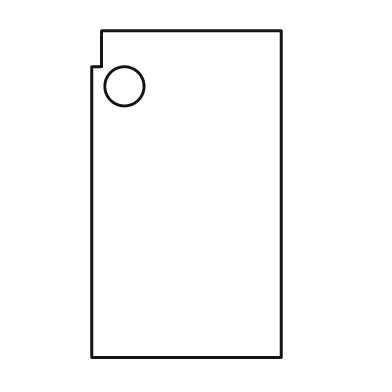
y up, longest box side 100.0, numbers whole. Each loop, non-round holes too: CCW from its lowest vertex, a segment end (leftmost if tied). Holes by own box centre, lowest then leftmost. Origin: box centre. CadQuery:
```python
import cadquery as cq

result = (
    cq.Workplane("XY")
    .moveTo(-29.0, -50.0)
    .lineTo(29.0, -50.0)
    .lineTo(29.0, 50.0)
    .lineTo(-26.0, 50.0)
    .lineTo(-26.0, 39.0)
    .lineTo(-29.0, 39.0)
    .close()
    .moveTo(-19.0, 33.0)
    .circle(6.0)
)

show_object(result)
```